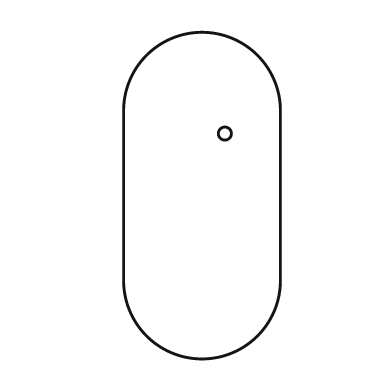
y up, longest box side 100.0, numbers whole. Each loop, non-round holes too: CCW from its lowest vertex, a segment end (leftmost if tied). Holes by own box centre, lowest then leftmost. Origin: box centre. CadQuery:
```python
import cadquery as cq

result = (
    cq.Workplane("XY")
    .moveTo(-24.0, -26.0)
    .threePointArc((0.0, -50.0), (24.0, -26.0))
    .lineTo(24.0, 26.0)
    .threePointArc((0.0, 50.0), (-24.0, 26.0))
    .close()
    .moveTo(7.0, 19.0)
    .circle(2.0)
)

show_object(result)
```